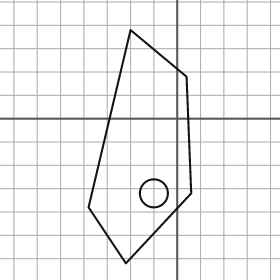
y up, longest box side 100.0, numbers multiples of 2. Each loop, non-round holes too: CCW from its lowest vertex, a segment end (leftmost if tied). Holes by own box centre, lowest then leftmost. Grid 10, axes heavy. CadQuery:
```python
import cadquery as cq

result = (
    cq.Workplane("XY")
    .moveTo(-22.0, -62.0)
    .lineTo(6.0, -32.0)
    .lineTo(4.0, 18.0)
    .lineTo(-20.0, 38.0)
    .lineTo(-38.0, -38.0)
    .close()
    .moveTo(-10.0, -32.0)
    .circle(6.0)
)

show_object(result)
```